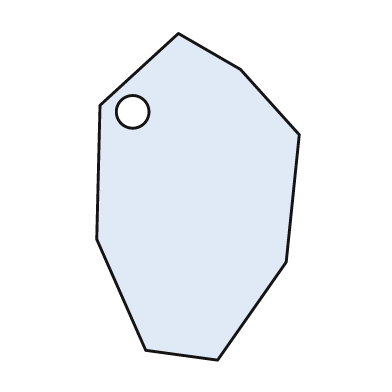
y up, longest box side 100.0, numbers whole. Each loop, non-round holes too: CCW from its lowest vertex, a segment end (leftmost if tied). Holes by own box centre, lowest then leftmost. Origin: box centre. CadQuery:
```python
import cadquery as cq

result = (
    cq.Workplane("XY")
    .moveTo(6.0, -50.0)
    .lineTo(27.0, -20.0)
    .lineTo(31.0, 19.0)
    .lineTo(13.0, 39.0)
    .lineTo(-6.0, 50.0)
    .lineTo(-30.0, 28.0)
    .lineTo(-31.0, -13.0)
    .lineTo(-16.0, -47.0)
    .close()
    .moveTo(-20.0, 26.0)
    .circle(5.0)
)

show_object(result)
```